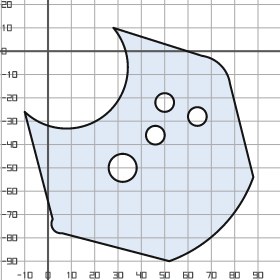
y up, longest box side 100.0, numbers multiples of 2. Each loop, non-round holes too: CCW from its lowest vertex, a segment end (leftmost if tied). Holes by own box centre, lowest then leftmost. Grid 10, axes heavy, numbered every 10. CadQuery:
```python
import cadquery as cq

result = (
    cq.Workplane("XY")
    .moveTo(52.0, -90.0)
    .threePointArc((74.0, -76.0), (88.0, -54.0))
    .lineTo(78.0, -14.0)
    .threePointArc((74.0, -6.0), (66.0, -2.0))
    .lineTo(28.0, 10.0)
    .threePointArc((26.0, -26.0), (-10.0, -26.0))
    .lineTo(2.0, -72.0)
    .threePointArc((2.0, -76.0), (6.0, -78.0))
    .close()
    .moveTo(32.0, -50.0)
    .circle(6.0)
    .moveTo(46.0, -36.0)
    .circle(4.0)
    .moveTo(64.0, -28.0)
    .circle(4.0)
    .moveTo(50.0, -22.0)
    .circle(4.0)
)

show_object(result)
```